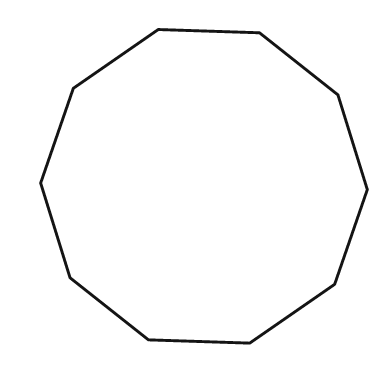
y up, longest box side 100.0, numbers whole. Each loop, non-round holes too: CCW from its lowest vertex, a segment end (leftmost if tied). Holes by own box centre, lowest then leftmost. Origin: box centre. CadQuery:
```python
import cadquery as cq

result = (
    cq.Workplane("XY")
    .moveTo(14.0, -48.0)
    .lineTo(40.0, -30.0)
    .lineTo(50.0, -1.0)
    .lineTo(41.0, 28.0)
    .lineTo(17.0, 47.0)
    .lineTo(-14.0, 48.0)
    .lineTo(-40.0, 30.0)
    .lineTo(-50.0, 1.0)
    .lineTo(-41.0, -28.0)
    .lineTo(-17.0, -47.0)
    .close()
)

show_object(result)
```